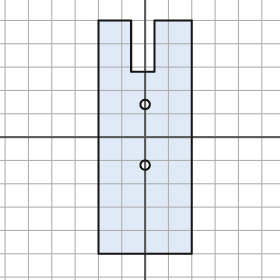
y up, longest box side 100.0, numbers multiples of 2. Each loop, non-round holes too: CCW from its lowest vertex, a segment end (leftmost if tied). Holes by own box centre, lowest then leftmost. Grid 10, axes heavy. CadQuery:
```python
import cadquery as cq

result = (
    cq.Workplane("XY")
    .moveTo(-20.0, -50.0)
    .lineTo(20.0, -50.0)
    .lineTo(20.0, 50.0)
    .lineTo(4.0, 50.0)
    .lineTo(4.0, 28.0)
    .lineTo(-6.0, 28.0)
    .lineTo(-6.0, 50.0)
    .lineTo(-20.0, 50.0)
    .close()
    .moveTo(0.0, -12.0)
    .circle(2.0)
    .moveTo(0.0, 14.0)
    .circle(2.0)
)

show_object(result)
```